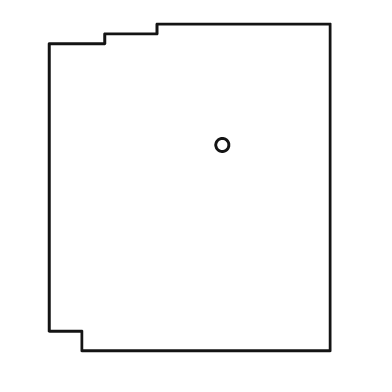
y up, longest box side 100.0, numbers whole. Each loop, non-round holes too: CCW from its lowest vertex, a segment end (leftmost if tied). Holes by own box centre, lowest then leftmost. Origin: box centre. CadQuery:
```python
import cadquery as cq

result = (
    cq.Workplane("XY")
    .moveTo(-33.0, -50.0)
    .lineTo(43.0, -50.0)
    .lineTo(43.0, 50.0)
    .lineTo(-10.0, 50.0)
    .lineTo(-10.0, 47.0)
    .lineTo(-26.0, 47.0)
    .lineTo(-26.0, 44.0)
    .lineTo(-43.0, 44.0)
    .lineTo(-43.0, -44.0)
    .lineTo(-33.0, -44.0)
    .close()
    .moveTo(10.0, 13.0)
    .circle(2.0)
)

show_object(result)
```